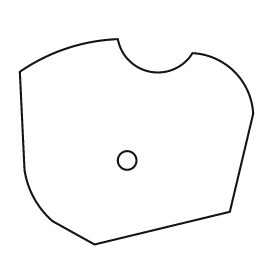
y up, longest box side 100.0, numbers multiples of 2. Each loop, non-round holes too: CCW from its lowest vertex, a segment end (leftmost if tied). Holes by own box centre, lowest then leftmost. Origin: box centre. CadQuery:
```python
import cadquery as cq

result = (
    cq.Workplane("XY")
    .moveTo(-18.0, -44.0)
    .lineTo(40.0, -30.0)
    .lineTo(50.0, 12.0)
    .threePointArc((42.0, 30.0), (24.0, 38.0))
    .threePointArc((6.0, 30.0), (-8.0, 44.0))
    .threePointArc((-30.0, 40.0), (-50.0, 30.0))
    .lineTo(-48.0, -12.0)
    .threePointArc((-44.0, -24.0), (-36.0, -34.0))
    .close()
    .moveTo(-4.0, -8.0)
    .circle(4.0)
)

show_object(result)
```